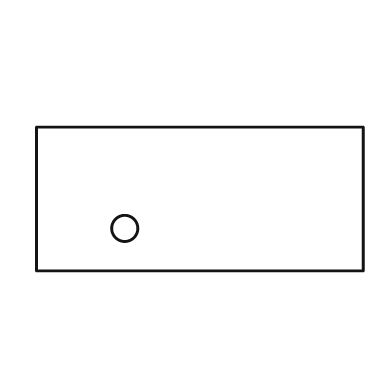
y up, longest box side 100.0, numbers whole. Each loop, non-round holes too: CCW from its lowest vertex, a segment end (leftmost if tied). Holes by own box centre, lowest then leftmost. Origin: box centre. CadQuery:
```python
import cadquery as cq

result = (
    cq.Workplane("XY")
    .moveTo(-50.0, -22.0)
    .lineTo(50.0, -22.0)
    .lineTo(50.0, 22.0)
    .lineTo(-50.0, 22.0)
    .close()
    .moveTo(-23.0, -9.0)
    .circle(4.0)
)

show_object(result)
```